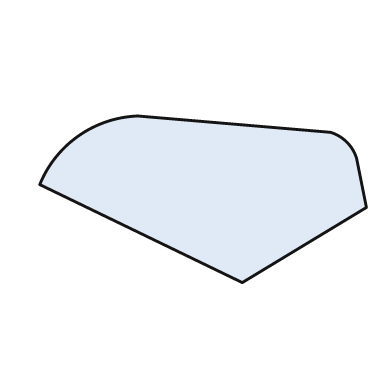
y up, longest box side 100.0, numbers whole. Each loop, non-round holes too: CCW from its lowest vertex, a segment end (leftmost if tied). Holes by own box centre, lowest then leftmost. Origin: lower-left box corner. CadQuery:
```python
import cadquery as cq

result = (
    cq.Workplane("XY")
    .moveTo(62.0, 0.0)
    .lineTo(100.0, 23.0)
    .lineTo(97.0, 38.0)
    .threePointArc((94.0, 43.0), (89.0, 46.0))
    .lineTo(30.0, 51.0)
    .threePointArc((12.0, 45.0), (0.0, 30.0))
    .close()
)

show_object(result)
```